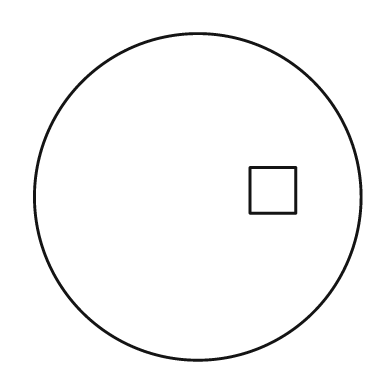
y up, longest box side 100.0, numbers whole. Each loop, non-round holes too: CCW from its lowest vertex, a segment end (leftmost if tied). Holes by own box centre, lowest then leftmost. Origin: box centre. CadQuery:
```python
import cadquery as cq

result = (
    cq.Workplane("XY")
    .moveTo(0.0, 0.0)
    .circle(50.0)
    .moveTo(16.0, -5.0)
    .lineTo(30.0, -5.0)
    .lineTo(30.0, 9.0)
    .lineTo(16.0, 9.0)
    .close()
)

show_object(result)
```